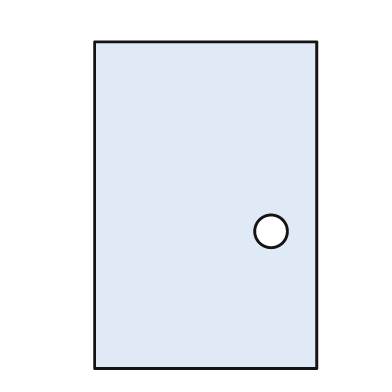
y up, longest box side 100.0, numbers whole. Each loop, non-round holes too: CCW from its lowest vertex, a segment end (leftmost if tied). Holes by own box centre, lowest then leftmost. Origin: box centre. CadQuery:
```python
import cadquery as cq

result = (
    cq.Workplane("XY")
    .moveTo(-34.0, -50.0)
    .lineTo(34.0, -50.0)
    .lineTo(34.0, 50.0)
    .lineTo(-34.0, 50.0)
    .close()
    .moveTo(20.0, -8.0)
    .circle(5.0)
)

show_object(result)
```